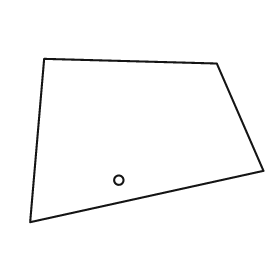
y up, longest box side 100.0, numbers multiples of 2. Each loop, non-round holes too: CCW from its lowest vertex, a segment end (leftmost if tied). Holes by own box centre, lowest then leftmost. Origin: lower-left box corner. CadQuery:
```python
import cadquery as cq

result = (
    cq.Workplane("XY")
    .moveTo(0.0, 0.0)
    .lineTo(100.0, 22.0)
    .lineTo(80.0, 68.0)
    .lineTo(6.0, 70.0)
    .close()
    .moveTo(38.0, 18.0)
    .circle(2.0)
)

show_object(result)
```